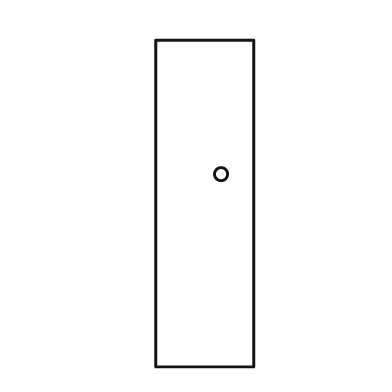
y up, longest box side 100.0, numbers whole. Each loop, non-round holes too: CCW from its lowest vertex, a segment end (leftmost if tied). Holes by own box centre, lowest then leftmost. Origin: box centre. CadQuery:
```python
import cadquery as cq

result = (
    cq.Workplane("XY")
    .moveTo(-15.0, -50.0)
    .lineTo(15.0, -50.0)
    .lineTo(15.0, 50.0)
    .lineTo(-15.0, 50.0)
    .close()
    .moveTo(5.0, 9.0)
    .circle(2.0)
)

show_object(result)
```